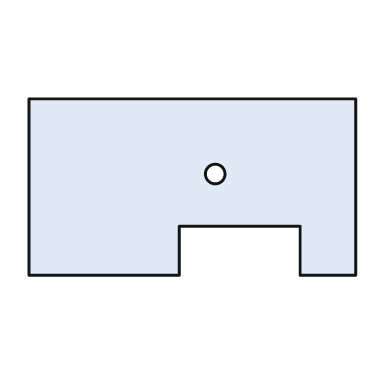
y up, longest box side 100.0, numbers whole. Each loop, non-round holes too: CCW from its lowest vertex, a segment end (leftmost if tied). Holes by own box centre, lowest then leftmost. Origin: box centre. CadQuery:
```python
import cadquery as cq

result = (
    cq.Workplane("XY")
    .moveTo(-50.0, -27.0)
    .lineTo(-4.0, -27.0)
    .lineTo(-4.0, -12.0)
    .lineTo(33.0, -12.0)
    .lineTo(33.0, -27.0)
    .lineTo(50.0, -27.0)
    .lineTo(50.0, 27.0)
    .lineTo(-50.0, 27.0)
    .close()
    .moveTo(7.0, 4.0)
    .circle(3.0)
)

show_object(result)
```